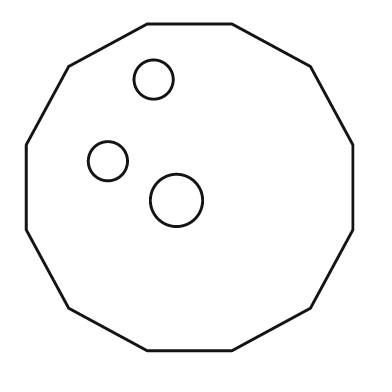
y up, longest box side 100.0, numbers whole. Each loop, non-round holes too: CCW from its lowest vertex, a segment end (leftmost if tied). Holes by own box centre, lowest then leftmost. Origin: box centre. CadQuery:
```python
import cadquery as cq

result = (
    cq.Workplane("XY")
    .moveTo(-13.0, -50.0)
    .lineTo(13.0, -50.0)
    .lineTo(37.0, -37.0)
    .lineTo(50.0, -13.0)
    .lineTo(50.0, 13.0)
    .lineTo(37.0, 37.0)
    .lineTo(13.0, 50.0)
    .lineTo(-13.0, 50.0)
    .lineTo(-37.0, 37.0)
    .lineTo(-50.0, 13.0)
    .lineTo(-50.0, -13.0)
    .lineTo(-37.0, -37.0)
    .close()
    .moveTo(-4.0, -4.0)
    .circle(8.0)
    .moveTo(-25.0, 8.0)
    .circle(6.0)
    .moveTo(-11.0, 33.0)
    .circle(6.0)
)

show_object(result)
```